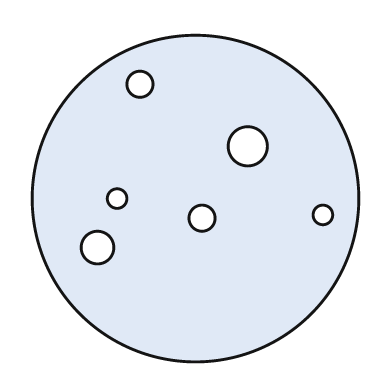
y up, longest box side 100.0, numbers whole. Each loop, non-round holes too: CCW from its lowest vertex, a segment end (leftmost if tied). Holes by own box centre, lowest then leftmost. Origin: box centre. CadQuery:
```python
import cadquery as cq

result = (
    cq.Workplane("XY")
    .moveTo(0.0, 0.0)
    .circle(50.0)
    .moveTo(-30.0, -15.0)
    .circle(5.0)
    .moveTo(2.0, -6.0)
    .circle(4.0)
    .moveTo(39.0, -5.0)
    .circle(3.0)
    .moveTo(-24.0, 0.0)
    .circle(3.0)
    .moveTo(16.0, 16.0)
    .circle(6.0)
    .moveTo(-17.0, 35.0)
    .circle(4.0)
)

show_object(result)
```